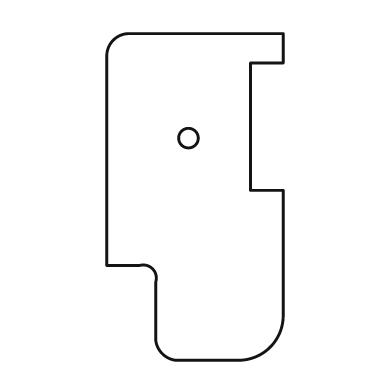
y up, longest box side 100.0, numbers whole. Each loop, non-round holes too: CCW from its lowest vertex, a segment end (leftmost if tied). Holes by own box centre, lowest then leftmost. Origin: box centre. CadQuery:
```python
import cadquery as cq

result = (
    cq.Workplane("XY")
    .moveTo(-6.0, -50.0)
    .lineTo(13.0, -50.0)
    .threePointArc((23.0, -46.0), (27.0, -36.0))
    .lineTo(27.0, 2.0)
    .lineTo(17.0, 2.0)
    .lineTo(17.0, 41.0)
    .lineTo(27.0, 41.0)
    .lineTo(27.0, 50.0)
    .lineTo(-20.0, 50.0)
    .threePointArc((-25.0, 48.0), (-27.0, 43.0))
    .lineTo(-27.0, -21.0)
    .lineTo(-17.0, -21.0)
    .threePointArc((-13.0, -22.0), (-12.0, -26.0))
    .lineTo(-12.0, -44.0)
    .threePointArc((-10.0, -48.0), (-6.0, -50.0))
    .close()
    .moveTo(-2.0, 18.0)
    .circle(3.0)
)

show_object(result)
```